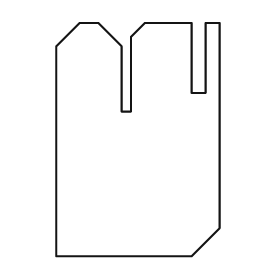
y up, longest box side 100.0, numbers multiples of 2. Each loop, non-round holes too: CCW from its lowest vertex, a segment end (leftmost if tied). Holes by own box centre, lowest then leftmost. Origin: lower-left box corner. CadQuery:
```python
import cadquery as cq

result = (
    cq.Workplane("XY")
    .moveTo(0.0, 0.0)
    .lineTo(58.0, 0.0)
    .lineTo(70.0, 12.0)
    .lineTo(70.0, 100.0)
    .lineTo(64.0, 100.0)
    .lineTo(64.0, 70.0)
    .lineTo(58.0, 70.0)
    .lineTo(58.0, 100.0)
    .lineTo(38.0, 100.0)
    .lineTo(32.0, 94.0)
    .lineTo(32.0, 62.0)
    .lineTo(28.0, 62.0)
    .lineTo(28.0, 90.0)
    .lineTo(18.0, 100.0)
    .lineTo(10.0, 100.0)
    .lineTo(0.0, 90.0)
    .close()
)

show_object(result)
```